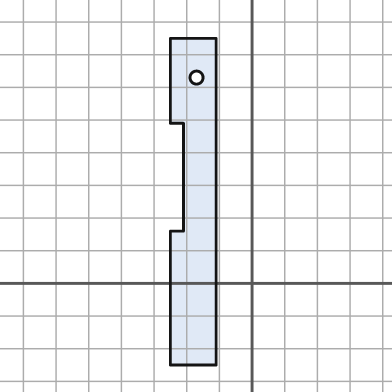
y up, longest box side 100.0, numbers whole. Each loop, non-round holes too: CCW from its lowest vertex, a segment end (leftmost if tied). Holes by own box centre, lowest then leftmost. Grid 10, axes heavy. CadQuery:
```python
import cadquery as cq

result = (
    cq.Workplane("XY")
    .moveTo(-25.0, -25.0)
    .lineTo(-11.0, -25.0)
    .lineTo(-11.0, 75.0)
    .lineTo(-25.0, 75.0)
    .lineTo(-25.0, 49.0)
    .lineTo(-21.0, 49.0)
    .lineTo(-21.0, 16.0)
    .lineTo(-25.0, 16.0)
    .close()
    .moveTo(-17.0, 63.0)
    .circle(2.0)
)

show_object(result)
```